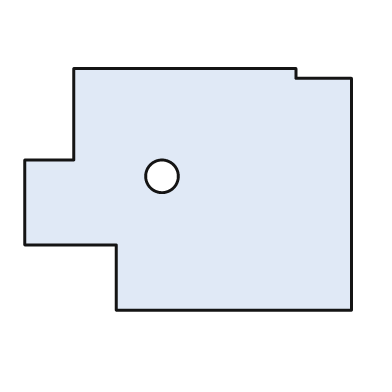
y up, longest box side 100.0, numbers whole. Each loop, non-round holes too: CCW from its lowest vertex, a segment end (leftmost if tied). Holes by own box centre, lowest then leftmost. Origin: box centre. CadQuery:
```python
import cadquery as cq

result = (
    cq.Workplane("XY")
    .moveTo(-22.0, -37.0)
    .lineTo(50.0, -37.0)
    .lineTo(50.0, 34.0)
    .lineTo(33.0, 34.0)
    .lineTo(33.0, 37.0)
    .lineTo(-35.0, 37.0)
    .lineTo(-35.0, 9.0)
    .lineTo(-50.0, 9.0)
    .lineTo(-50.0, -17.0)
    .lineTo(-22.0, -17.0)
    .close()
    .moveTo(-8.0, 4.0)
    .circle(5.0)
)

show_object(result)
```